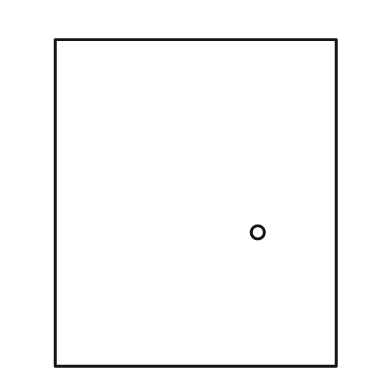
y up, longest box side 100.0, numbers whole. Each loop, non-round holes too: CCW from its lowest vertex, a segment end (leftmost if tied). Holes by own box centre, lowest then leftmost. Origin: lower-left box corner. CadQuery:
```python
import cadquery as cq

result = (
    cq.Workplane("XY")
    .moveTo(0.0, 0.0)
    .lineTo(86.0, 0.0)
    .lineTo(86.0, 100.0)
    .lineTo(0.0, 100.0)
    .close()
    .moveTo(62.0, 41.0)
    .circle(2.0)
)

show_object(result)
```